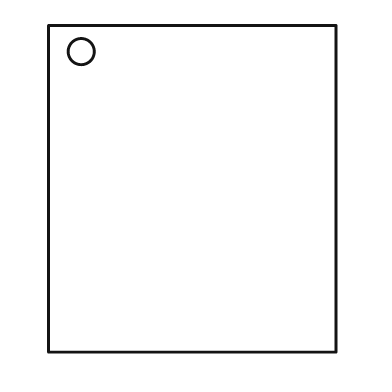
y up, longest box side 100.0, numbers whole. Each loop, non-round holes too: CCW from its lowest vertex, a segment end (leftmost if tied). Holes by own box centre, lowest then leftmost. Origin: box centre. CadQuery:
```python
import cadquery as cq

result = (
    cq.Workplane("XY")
    .moveTo(-44.0, -50.0)
    .lineTo(44.0, -50.0)
    .lineTo(44.0, 50.0)
    .lineTo(-44.0, 50.0)
    .close()
    .moveTo(-34.0, 42.0)
    .circle(4.0)
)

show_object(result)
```